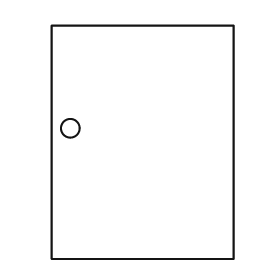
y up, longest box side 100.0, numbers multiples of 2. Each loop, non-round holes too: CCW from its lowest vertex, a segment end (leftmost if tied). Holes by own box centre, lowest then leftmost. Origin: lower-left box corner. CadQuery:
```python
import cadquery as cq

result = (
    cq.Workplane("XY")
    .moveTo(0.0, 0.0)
    .lineTo(78.0, 0.0)
    .lineTo(78.0, 100.0)
    .lineTo(0.0, 100.0)
    .close()
    .moveTo(8.0, 56.0)
    .circle(4.0)
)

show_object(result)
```